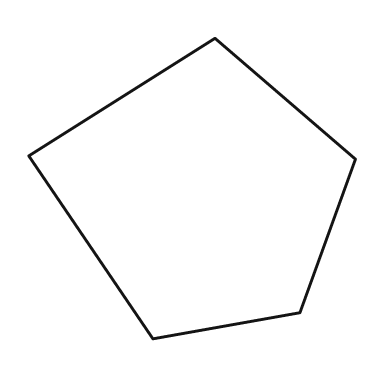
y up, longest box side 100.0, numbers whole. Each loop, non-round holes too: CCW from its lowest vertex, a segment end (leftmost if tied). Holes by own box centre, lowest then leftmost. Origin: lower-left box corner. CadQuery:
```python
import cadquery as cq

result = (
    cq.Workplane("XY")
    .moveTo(38.0, 0.0)
    .lineTo(83.0, 8.0)
    .lineTo(100.0, 55.0)
    .lineTo(57.0, 92.0)
    .lineTo(0.0, 56.0)
    .close()
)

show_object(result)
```